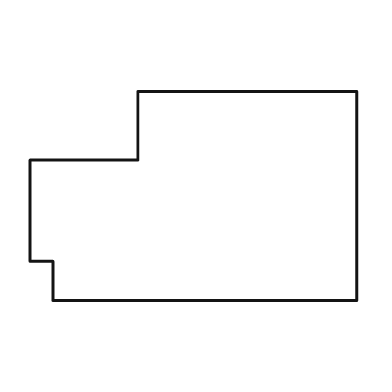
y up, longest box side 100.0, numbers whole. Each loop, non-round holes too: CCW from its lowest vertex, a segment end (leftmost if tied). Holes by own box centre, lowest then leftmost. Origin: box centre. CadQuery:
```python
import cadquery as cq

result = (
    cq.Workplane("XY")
    .moveTo(-43.0, -32.0)
    .lineTo(50.0, -32.0)
    .lineTo(50.0, 32.0)
    .lineTo(-17.0, 32.0)
    .lineTo(-17.0, 11.0)
    .lineTo(-50.0, 11.0)
    .lineTo(-50.0, -20.0)
    .lineTo(-43.0, -20.0)
    .close()
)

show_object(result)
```